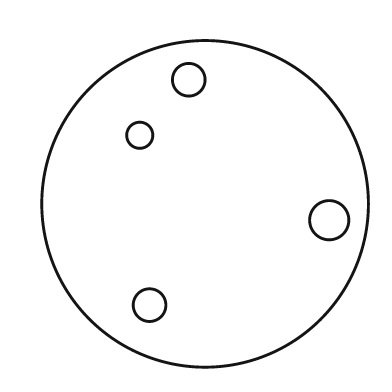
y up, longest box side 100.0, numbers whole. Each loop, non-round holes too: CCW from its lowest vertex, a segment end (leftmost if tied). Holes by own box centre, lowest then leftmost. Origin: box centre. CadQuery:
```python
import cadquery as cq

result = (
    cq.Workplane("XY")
    .moveTo(0.0, 0.0)
    .circle(50.0)
    .moveTo(-17.0, -31.0)
    .circle(5.0)
    .moveTo(38.0, -5.0)
    .circle(6.0)
    .moveTo(-20.0, 21.0)
    .circle(4.0)
    .moveTo(-5.0, 38.0)
    .circle(5.0)
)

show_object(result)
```